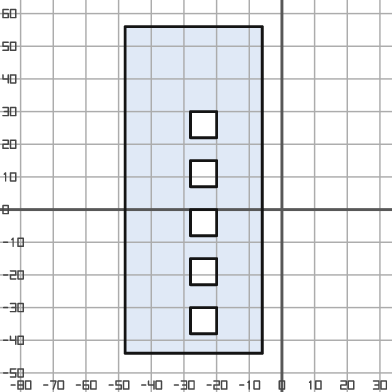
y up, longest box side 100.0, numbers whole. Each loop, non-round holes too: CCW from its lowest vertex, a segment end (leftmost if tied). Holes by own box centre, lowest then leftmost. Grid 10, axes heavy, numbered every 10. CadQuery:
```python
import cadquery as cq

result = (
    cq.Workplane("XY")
    .moveTo(-48.0, -44.0)
    .lineTo(-6.0, -44.0)
    .lineTo(-6.0, 56.0)
    .lineTo(-48.0, 56.0)
    .close()
    .moveTo(-28.0, -38.0)
    .lineTo(-20.0, -38.0)
    .lineTo(-20.0, -30.0)
    .lineTo(-28.0, -30.0)
    .close()
    .moveTo(-28.0, -23.0)
    .lineTo(-20.0, -23.0)
    .lineTo(-20.0, -15.0)
    .lineTo(-28.0, -15.0)
    .close()
    .moveTo(-28.0, -8.0)
    .lineTo(-20.0, -8.0)
    .lineTo(-20.0, 0.0)
    .lineTo(-28.0, 0.0)
    .close()
    .moveTo(-28.0, 7.0)
    .lineTo(-20.0, 7.0)
    .lineTo(-20.0, 15.0)
    .lineTo(-28.0, 15.0)
    .close()
    .moveTo(-28.0, 22.0)
    .lineTo(-20.0, 22.0)
    .lineTo(-20.0, 30.0)
    .lineTo(-28.0, 30.0)
    .close()
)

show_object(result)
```